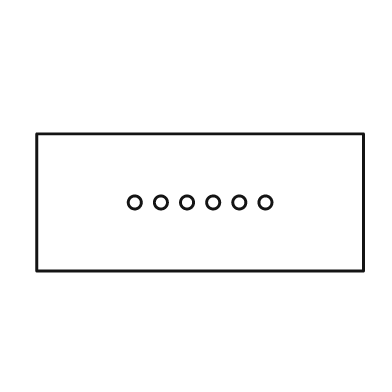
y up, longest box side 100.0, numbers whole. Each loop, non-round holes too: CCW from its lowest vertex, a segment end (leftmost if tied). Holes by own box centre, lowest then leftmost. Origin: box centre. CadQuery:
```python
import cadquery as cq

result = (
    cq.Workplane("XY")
    .moveTo(-50.0, -21.0)
    .lineTo(50.0, -21.0)
    .lineTo(50.0, 21.0)
    .lineTo(-50.0, 21.0)
    .close()
    .moveTo(-20.0, 0.0)
    .circle(2.0)
    .moveTo(-12.0, 0.0)
    .circle(2.0)
    .moveTo(-4.0, 0.0)
    .circle(2.0)
    .moveTo(4.0, 0.0)
    .circle(2.0)
    .moveTo(12.0, 0.0)
    .circle(2.0)
    .moveTo(20.0, 0.0)
    .circle(2.0)
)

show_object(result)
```